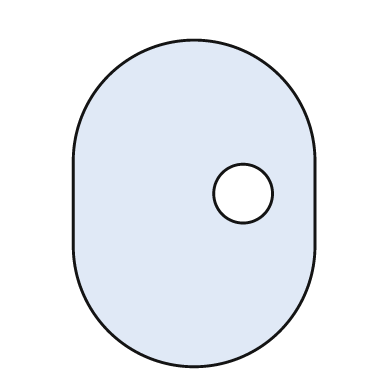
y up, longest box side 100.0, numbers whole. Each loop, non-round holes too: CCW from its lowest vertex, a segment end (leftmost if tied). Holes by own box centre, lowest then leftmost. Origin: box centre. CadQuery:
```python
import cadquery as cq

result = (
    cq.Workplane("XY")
    .moveTo(-37.0, -13.0)
    .threePointArc((0.0, -50.0), (37.0, -13.0))
    .lineTo(37.0, 13.0)
    .threePointArc((0.0, 50.0), (-37.0, 13.0))
    .close()
    .moveTo(15.0, 3.0)
    .circle(9.0)
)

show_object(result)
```